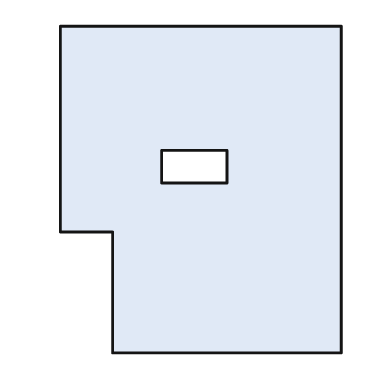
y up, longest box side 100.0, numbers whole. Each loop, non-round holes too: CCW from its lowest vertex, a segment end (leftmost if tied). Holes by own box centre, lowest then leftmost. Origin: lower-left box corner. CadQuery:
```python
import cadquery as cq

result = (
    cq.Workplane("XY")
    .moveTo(16.0, 0.0)
    .lineTo(86.0, 0.0)
    .lineTo(86.0, 100.0)
    .lineTo(0.0, 100.0)
    .lineTo(0.0, 37.0)
    .lineTo(16.0, 37.0)
    .close()
    .moveTo(31.0, 52.0)
    .lineTo(51.0, 52.0)
    .lineTo(51.0, 62.0)
    .lineTo(31.0, 62.0)
    .close()
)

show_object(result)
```